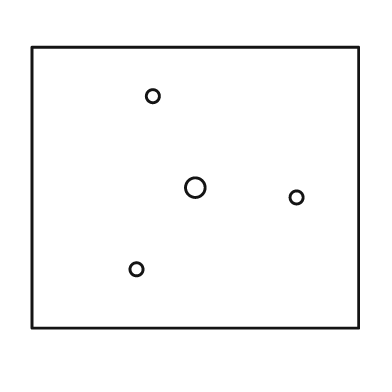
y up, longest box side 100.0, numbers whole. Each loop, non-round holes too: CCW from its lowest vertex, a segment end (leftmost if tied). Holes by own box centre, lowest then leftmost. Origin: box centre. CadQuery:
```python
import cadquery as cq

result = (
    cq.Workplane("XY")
    .moveTo(-50.0, -43.0)
    .lineTo(50.0, -43.0)
    .lineTo(50.0, 43.0)
    .lineTo(-50.0, 43.0)
    .close()
    .moveTo(-18.0, -25.0)
    .circle(2.0)
    .moveTo(31.0, -3.0)
    .circle(2.0)
    .moveTo(0.0, 0.0)
    .circle(3.0)
    .moveTo(-13.0, 28.0)
    .circle(2.0)
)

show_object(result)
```